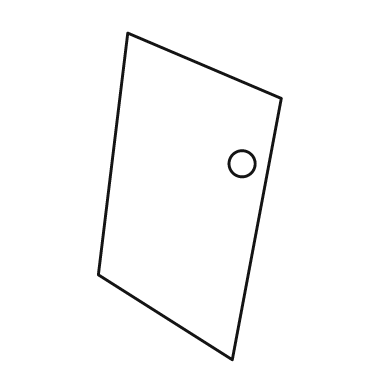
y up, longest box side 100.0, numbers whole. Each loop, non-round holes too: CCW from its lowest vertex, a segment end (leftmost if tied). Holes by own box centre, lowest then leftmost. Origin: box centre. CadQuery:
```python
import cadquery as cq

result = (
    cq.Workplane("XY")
    .moveTo(13.0, -50.0)
    .lineTo(28.0, 30.0)
    .lineTo(-19.0, 50.0)
    .lineTo(-28.0, -24.0)
    .close()
    .moveTo(16.0, 10.0)
    .circle(4.0)
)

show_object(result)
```